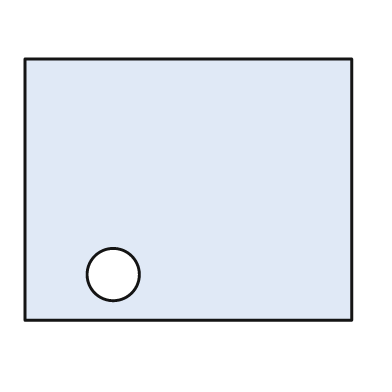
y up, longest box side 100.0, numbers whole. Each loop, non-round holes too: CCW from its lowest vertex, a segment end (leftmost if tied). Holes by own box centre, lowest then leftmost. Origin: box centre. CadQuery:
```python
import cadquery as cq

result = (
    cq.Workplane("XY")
    .moveTo(-50.0, -40.0)
    .lineTo(50.0, -40.0)
    .lineTo(50.0, 40.0)
    .lineTo(-50.0, 40.0)
    .close()
    .moveTo(-23.0, -26.0)
    .circle(8.0)
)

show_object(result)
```